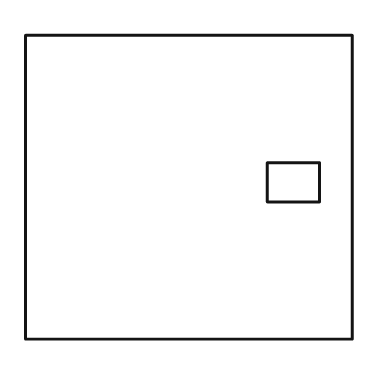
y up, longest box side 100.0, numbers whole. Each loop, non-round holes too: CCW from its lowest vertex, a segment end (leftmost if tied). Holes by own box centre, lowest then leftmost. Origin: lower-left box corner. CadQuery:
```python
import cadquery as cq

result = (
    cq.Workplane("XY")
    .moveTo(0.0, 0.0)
    .lineTo(100.0, 0.0)
    .lineTo(100.0, 93.0)
    .lineTo(0.0, 93.0)
    .close()
    .moveTo(74.0, 42.0)
    .lineTo(90.0, 42.0)
    .lineTo(90.0, 54.0)
    .lineTo(74.0, 54.0)
    .close()
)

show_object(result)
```